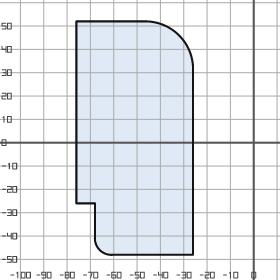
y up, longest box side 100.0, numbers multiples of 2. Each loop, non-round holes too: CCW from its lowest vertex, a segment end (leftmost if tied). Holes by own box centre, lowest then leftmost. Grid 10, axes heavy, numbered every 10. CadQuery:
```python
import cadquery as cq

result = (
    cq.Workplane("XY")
    .moveTo(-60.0, -48.0)
    .lineTo(-26.0, -48.0)
    .lineTo(-26.0, 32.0)
    .threePointArc((-32.0, 46.0), (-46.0, 52.0))
    .lineTo(-76.0, 52.0)
    .lineTo(-76.0, -26.0)
    .lineTo(-68.0, -26.0)
    .lineTo(-68.0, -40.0)
    .threePointArc((-66.0, -46.0), (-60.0, -48.0))
    .close()
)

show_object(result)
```